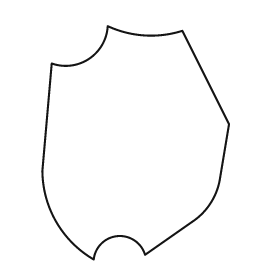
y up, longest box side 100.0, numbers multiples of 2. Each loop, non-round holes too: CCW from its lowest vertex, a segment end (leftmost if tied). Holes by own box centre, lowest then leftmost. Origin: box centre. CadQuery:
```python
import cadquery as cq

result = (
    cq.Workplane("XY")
    .moveTo(-18.0, -50.0)
    .threePointArc((-8.0, -40.0), (4.0, -48.0))
    .lineTo(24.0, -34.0)
    .threePointArc((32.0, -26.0), (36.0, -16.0))
    .lineTo(40.0, 8.0)
    .lineTo(20.0, 48.0)
    .threePointArc((4.0, 46.0), (-12.0, 50.0))
    .threePointArc((-20.0, 36.0), (-36.0, 34.0))
    .lineTo(-40.0, -12.0)
    .threePointArc((-34.0, -34.0), (-18.0, -50.0))
    .close()
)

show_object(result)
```